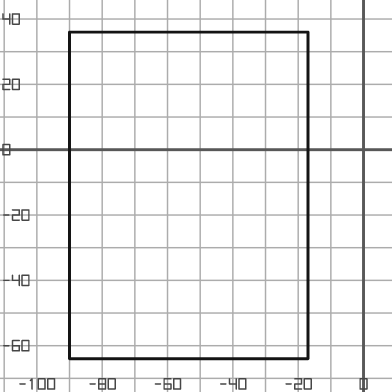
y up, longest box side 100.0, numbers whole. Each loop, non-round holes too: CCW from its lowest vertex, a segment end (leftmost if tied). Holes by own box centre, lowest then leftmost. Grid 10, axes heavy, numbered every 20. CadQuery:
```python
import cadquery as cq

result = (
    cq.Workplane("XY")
    .moveTo(-90.0, -64.0)
    .lineTo(-17.0, -64.0)
    .lineTo(-17.0, 36.0)
    .lineTo(-90.0, 36.0)
    .close()
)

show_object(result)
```